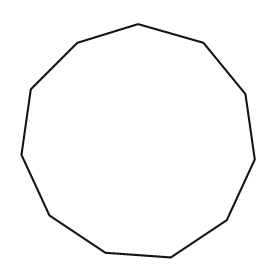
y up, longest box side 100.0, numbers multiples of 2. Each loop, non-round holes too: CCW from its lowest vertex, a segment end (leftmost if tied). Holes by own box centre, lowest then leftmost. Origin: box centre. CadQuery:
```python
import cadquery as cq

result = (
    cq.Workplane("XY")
    .moveTo(14.0, -50.0)
    .lineTo(38.0, -34.0)
    .lineTo(50.0, -8.0)
    .lineTo(46.0, 20.0)
    .lineTo(28.0, 42.0)
    .lineTo(0.0, 50.0)
    .lineTo(-26.0, 42.0)
    .lineTo(-46.0, 22.0)
    .lineTo(-50.0, -6.0)
    .lineTo(-38.0, -32.0)
    .lineTo(-14.0, -48.0)
    .close()
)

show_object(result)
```